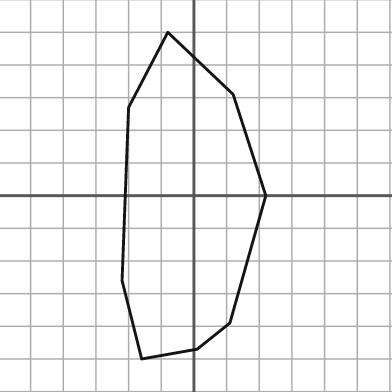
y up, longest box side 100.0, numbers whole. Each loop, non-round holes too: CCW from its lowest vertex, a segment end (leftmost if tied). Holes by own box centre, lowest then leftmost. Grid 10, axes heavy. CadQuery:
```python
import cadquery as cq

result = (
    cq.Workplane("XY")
    .moveTo(-16.0, -50.0)
    .lineTo(1.0, -47.0)
    .lineTo(11.0, -39.0)
    .lineTo(22.0, 0.0)
    .lineTo(12.0, 31.0)
    .lineTo(-8.0, 50.0)
    .lineTo(-20.0, 27.0)
    .lineTo(-22.0, -26.0)
    .close()
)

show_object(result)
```